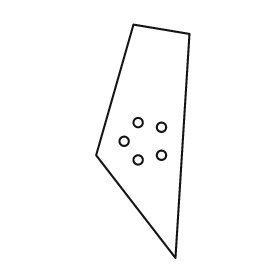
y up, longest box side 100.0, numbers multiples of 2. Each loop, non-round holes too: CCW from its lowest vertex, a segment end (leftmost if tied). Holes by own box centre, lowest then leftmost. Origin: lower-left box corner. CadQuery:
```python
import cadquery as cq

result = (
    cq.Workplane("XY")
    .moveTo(34.0, 0.0)
    .lineTo(40.0, 96.0)
    .lineTo(16.0, 100.0)
    .lineTo(0.0, 44.0)
    .close()
    .moveTo(18.0, 42.0)
    .circle(2.0)
    .moveTo(28.0, 44.0)
    .circle(2.0)
    .moveTo(12.0, 50.0)
    .circle(2.0)
    .moveTo(28.0, 56.0)
    .circle(2.0)
    .moveTo(18.0, 58.0)
    .circle(2.0)
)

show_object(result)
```